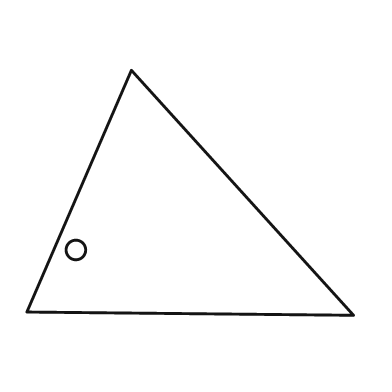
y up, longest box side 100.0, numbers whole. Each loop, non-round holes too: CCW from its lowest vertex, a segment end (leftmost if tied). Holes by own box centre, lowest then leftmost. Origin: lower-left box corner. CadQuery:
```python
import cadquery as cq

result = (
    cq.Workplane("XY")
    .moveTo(100.0, 0.0)
    .lineTo(32.0, 75.0)
    .lineTo(0.0, 1.0)
    .close()
    .moveTo(15.0, 20.0)
    .circle(3.0)
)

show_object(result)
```